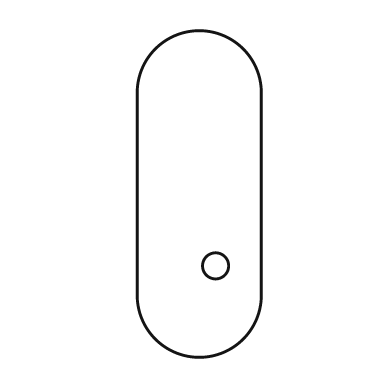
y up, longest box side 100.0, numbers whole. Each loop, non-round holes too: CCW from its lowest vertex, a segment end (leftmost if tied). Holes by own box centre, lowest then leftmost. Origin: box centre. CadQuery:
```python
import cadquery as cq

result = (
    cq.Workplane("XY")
    .moveTo(-19.0, -31.0)
    .threePointArc((0.0, -50.0), (19.0, -31.0))
    .lineTo(19.0, 31.0)
    .threePointArc((0.0, 50.0), (-19.0, 31.0))
    .close()
    .moveTo(5.0, -22.0)
    .circle(4.0)
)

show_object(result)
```